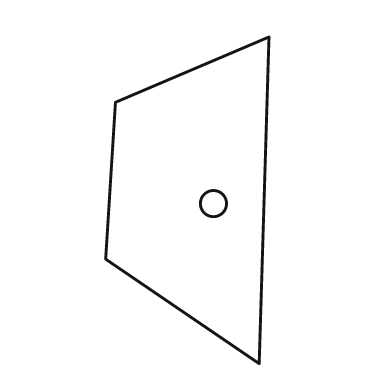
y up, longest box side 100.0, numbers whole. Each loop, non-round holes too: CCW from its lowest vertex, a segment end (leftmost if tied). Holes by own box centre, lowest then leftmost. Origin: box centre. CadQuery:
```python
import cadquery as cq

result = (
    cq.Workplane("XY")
    .moveTo(22.0, -50.0)
    .lineTo(25.0, 50.0)
    .lineTo(-22.0, 30.0)
    .lineTo(-25.0, -18.0)
    .close()
    .moveTo(8.0, -1.0)
    .circle(4.0)
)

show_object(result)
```